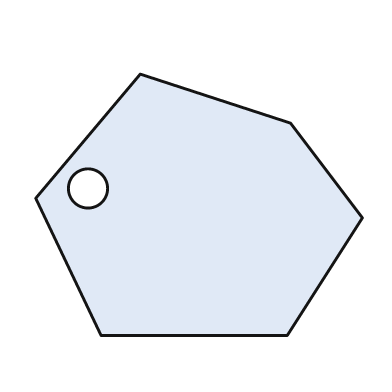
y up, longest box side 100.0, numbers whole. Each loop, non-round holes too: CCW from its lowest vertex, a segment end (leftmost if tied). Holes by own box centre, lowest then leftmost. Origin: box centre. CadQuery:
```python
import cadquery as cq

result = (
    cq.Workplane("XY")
    .moveTo(-30.0, -40.0)
    .lineTo(27.0, -40.0)
    .lineTo(50.0, -4.0)
    .lineTo(28.0, 25.0)
    .lineTo(-18.0, 40.0)
    .lineTo(-50.0, 2.0)
    .close()
    .moveTo(-34.0, 5.0)
    .circle(6.0)
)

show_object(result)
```